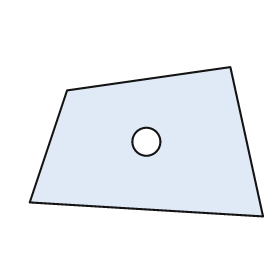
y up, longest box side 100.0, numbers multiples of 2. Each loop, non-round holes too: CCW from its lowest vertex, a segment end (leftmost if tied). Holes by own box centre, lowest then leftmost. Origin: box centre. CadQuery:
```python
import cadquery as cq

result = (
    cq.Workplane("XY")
    .moveTo(50.0, -32.0)
    .lineTo(36.0, 32.0)
    .lineTo(-34.0, 22.0)
    .lineTo(-50.0, -26.0)
    .close()
    .moveTo(0.0, 0.0)
    .circle(6.0)
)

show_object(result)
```